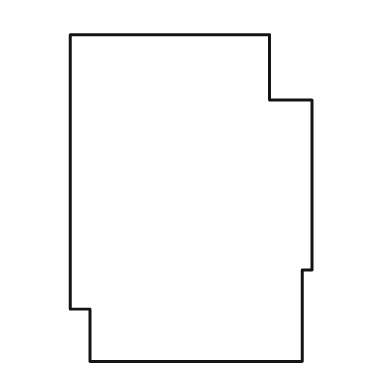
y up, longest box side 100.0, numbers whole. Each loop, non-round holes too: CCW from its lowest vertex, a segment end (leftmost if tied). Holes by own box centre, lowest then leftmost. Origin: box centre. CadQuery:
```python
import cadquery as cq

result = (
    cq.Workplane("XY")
    .moveTo(-31.0, -50.0)
    .lineTo(34.0, -50.0)
    .lineTo(34.0, -22.0)
    .lineTo(37.0, -22.0)
    .lineTo(37.0, 30.0)
    .lineTo(24.0, 30.0)
    .lineTo(24.0, 50.0)
    .lineTo(-37.0, 50.0)
    .lineTo(-37.0, -34.0)
    .lineTo(-31.0, -34.0)
    .close()
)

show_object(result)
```